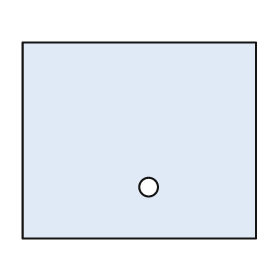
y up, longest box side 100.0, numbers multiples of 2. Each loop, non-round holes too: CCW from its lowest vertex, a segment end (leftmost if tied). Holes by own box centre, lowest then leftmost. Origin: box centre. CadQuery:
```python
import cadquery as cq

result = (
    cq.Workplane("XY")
    .moveTo(-50.0, -42.0)
    .lineTo(50.0, -42.0)
    .lineTo(50.0, 42.0)
    .lineTo(-50.0, 42.0)
    .close()
    .moveTo(4.0, -20.0)
    .circle(4.0)
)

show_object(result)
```